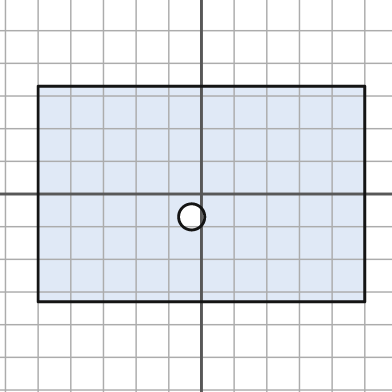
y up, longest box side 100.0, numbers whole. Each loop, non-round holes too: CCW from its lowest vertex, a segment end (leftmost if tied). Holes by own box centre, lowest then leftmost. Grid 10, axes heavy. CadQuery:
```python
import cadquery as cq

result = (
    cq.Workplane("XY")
    .moveTo(-50.0, -33.0)
    .lineTo(50.0, -33.0)
    .lineTo(50.0, 33.0)
    .lineTo(-50.0, 33.0)
    .close()
    .moveTo(-3.0, -7.0)
    .circle(4.0)
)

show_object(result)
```